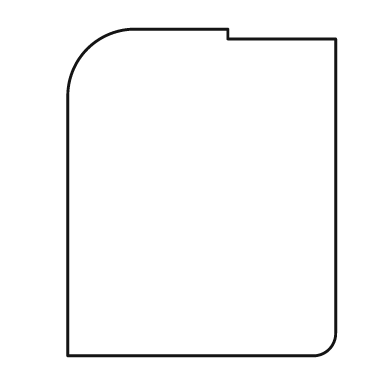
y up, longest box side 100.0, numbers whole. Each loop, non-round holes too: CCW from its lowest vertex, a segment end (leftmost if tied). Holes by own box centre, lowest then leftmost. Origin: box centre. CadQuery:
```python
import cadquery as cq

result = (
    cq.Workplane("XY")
    .moveTo(-41.0, -50.0)
    .lineTo(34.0, -50.0)
    .threePointArc((39.0, -48.0), (41.0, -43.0))
    .lineTo(41.0, 47.0)
    .lineTo(8.0, 47.0)
    .lineTo(8.0, 50.0)
    .lineTo(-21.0, 50.0)
    .threePointArc((-35.0, 44.0), (-41.0, 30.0))
    .close()
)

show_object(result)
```